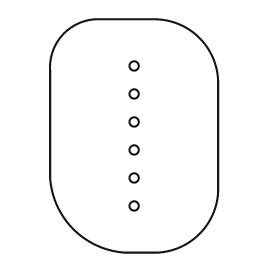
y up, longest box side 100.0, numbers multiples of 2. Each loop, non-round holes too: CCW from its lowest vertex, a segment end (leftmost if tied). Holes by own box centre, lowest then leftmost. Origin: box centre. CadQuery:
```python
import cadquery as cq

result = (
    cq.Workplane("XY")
    .moveTo(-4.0, -50.0)
    .lineTo(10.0, -50.0)
    .threePointArc((28.0, -42.0), (36.0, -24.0))
    .lineTo(36.0, 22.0)
    .threePointArc((28.0, 42.0), (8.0, 50.0))
    .lineTo(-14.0, 50.0)
    .threePointArc((-30.0, 44.0), (-36.0, 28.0))
    .lineTo(-36.0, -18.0)
    .threePointArc((-26.0, -40.0), (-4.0, -50.0))
    .close()
    .moveTo(0.0, -30.0)
    .circle(2.0)
    .moveTo(0.0, -18.0)
    .circle(2.0)
    .moveTo(0.0, -6.0)
    .circle(2.0)
    .moveTo(0.0, 6.0)
    .circle(2.0)
    .moveTo(0.0, 18.0)
    .circle(2.0)
    .moveTo(0.0, 30.0)
    .circle(2.0)
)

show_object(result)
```